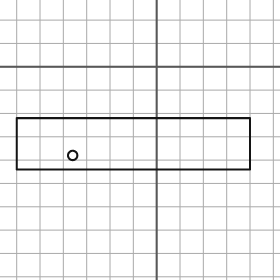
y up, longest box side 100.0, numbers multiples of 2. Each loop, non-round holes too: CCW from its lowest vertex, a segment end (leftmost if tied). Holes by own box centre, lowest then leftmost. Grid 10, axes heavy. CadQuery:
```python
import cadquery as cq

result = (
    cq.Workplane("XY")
    .moveTo(-60.0, -44.0)
    .lineTo(40.0, -44.0)
    .lineTo(40.0, -22.0)
    .lineTo(-60.0, -22.0)
    .close()
    .moveTo(-36.0, -38.0)
    .circle(2.0)
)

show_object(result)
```